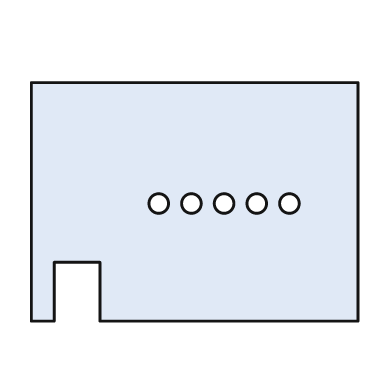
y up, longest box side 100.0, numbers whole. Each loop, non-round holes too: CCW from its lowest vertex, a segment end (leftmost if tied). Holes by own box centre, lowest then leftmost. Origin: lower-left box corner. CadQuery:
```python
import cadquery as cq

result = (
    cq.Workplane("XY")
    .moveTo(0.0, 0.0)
    .lineTo(7.0, 0.0)
    .lineTo(7.0, 18.0)
    .lineTo(21.0, 18.0)
    .lineTo(21.0, 0.0)
    .lineTo(100.0, 0.0)
    .lineTo(100.0, 73.0)
    .lineTo(0.0, 73.0)
    .close()
    .moveTo(39.0, 36.0)
    .circle(3.0)
    .moveTo(49.0, 36.0)
    .circle(3.0)
    .moveTo(59.0, 36.0)
    .circle(3.0)
    .moveTo(69.0, 36.0)
    .circle(3.0)
    .moveTo(79.0, 36.0)
    .circle(3.0)
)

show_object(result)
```